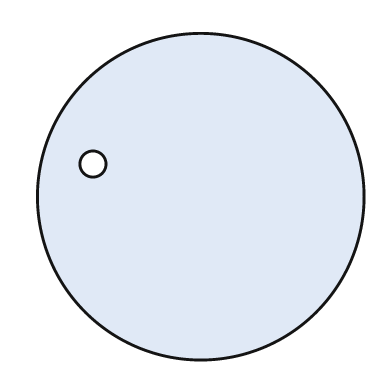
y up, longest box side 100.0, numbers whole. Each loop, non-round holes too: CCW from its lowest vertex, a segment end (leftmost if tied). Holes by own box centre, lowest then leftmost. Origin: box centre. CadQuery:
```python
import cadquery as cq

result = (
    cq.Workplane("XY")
    .moveTo(0.0, 0.0)
    .circle(50.0)
    .moveTo(-33.0, 10.0)
    .circle(4.0)
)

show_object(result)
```